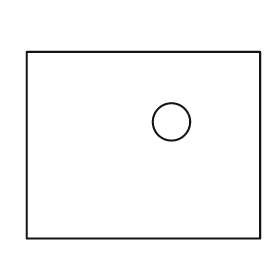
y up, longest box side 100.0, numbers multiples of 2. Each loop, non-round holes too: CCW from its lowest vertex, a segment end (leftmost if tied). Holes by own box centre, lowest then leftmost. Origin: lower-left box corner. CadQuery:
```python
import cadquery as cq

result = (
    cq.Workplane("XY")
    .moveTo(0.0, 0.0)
    .lineTo(100.0, 0.0)
    .lineTo(100.0, 80.0)
    .lineTo(0.0, 80.0)
    .close()
    .moveTo(62.0, 50.0)
    .circle(8.0)
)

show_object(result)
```